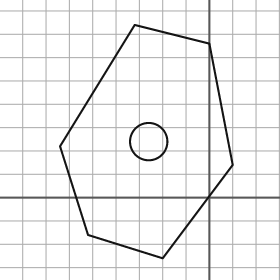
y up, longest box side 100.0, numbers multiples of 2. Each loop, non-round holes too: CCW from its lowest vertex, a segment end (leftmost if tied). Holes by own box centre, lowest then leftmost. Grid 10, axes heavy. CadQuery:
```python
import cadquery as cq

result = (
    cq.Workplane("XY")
    .moveTo(-20.0, -26.0)
    .lineTo(10.0, 14.0)
    .lineTo(0.0, 66.0)
    .lineTo(-32.0, 74.0)
    .lineTo(-64.0, 22.0)
    .lineTo(-52.0, -16.0)
    .close()
    .moveTo(-26.0, 24.0)
    .circle(8.0)
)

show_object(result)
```